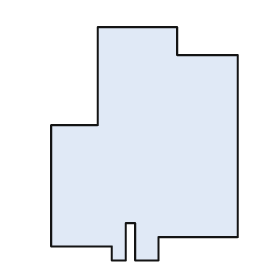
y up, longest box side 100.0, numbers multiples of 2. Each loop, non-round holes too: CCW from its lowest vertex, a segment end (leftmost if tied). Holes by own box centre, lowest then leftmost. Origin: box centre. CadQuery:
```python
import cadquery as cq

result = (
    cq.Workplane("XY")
    .moveTo(-14.0, -50.0)
    .lineTo(-8.0, -50.0)
    .lineTo(-8.0, -34.0)
    .lineTo(-4.0, -34.0)
    .lineTo(-4.0, -50.0)
    .lineTo(6.0, -50.0)
    .lineTo(6.0, -40.0)
    .lineTo(40.0, -40.0)
    .lineTo(40.0, 38.0)
    .lineTo(14.0, 38.0)
    .lineTo(14.0, 50.0)
    .lineTo(-20.0, 50.0)
    .lineTo(-20.0, 8.0)
    .lineTo(-40.0, 8.0)
    .lineTo(-40.0, -44.0)
    .lineTo(-14.0, -44.0)
    .close()
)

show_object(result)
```